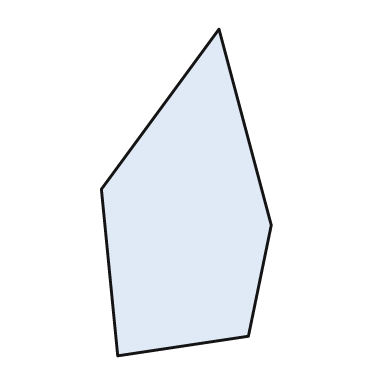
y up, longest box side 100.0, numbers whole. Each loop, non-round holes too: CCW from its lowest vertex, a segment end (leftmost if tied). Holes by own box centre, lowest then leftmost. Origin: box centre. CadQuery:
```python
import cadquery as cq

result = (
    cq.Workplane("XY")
    .moveTo(-21.0, -50.0)
    .lineTo(19.0, -44.0)
    .lineTo(26.0, -10.0)
    .lineTo(10.0, 50.0)
    .lineTo(-26.0, 1.0)
    .close()
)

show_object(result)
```